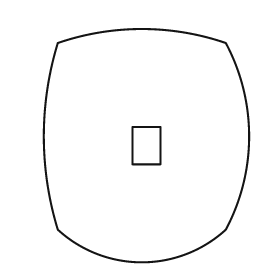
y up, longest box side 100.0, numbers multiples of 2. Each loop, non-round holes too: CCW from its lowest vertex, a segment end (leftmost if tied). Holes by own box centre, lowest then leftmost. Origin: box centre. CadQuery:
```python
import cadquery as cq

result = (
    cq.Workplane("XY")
    .moveTo(-38.0, -36.0)
    .threePointArc((-2.0, -50.0), (34.0, -36.0))
    .threePointArc((44.0, 4.0), (34.0, 44.0))
    .threePointArc((-2.0, 50.0), (-38.0, 44.0))
    .threePointArc((-44.0, 4.0), (-38.0, -36.0))
    .close()
    .moveTo(-6.0, -8.0)
    .lineTo(6.0, -8.0)
    .lineTo(6.0, 8.0)
    .lineTo(-6.0, 8.0)
    .close()
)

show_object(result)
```